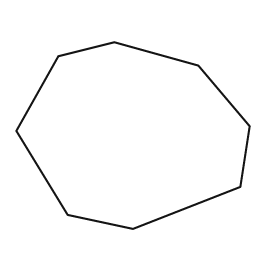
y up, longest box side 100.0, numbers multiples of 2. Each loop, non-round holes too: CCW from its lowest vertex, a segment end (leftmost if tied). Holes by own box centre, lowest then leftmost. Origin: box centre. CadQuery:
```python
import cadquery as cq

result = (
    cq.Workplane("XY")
    .moveTo(0.0, -40.0)
    .lineTo(46.0, -22.0)
    .lineTo(50.0, 4.0)
    .lineTo(28.0, 30.0)
    .lineTo(-8.0, 40.0)
    .lineTo(-32.0, 34.0)
    .lineTo(-50.0, 2.0)
    .lineTo(-28.0, -34.0)
    .close()
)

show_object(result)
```